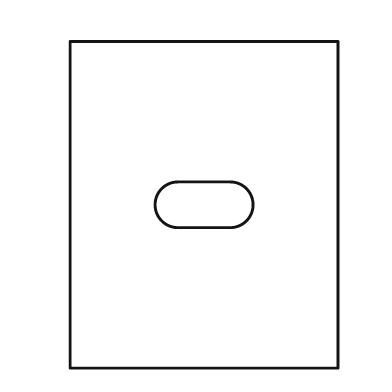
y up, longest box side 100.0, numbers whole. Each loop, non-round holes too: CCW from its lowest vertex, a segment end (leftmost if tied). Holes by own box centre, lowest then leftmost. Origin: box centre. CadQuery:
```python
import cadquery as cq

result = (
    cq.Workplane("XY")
    .moveTo(-41.0, -50.0)
    .lineTo(41.0, -50.0)
    .lineTo(41.0, 50.0)
    .lineTo(-41.0, 50.0)
    .close()
    .moveTo(-8.0, -7.0)
    .lineTo(8.0, -7.0)
    .threePointArc((15.0, 0.0), (8.0, 7.0))
    .lineTo(-8.0, 7.0)
    .threePointArc((-15.0, 0.0), (-8.0, -7.0))
    .close()
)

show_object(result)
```